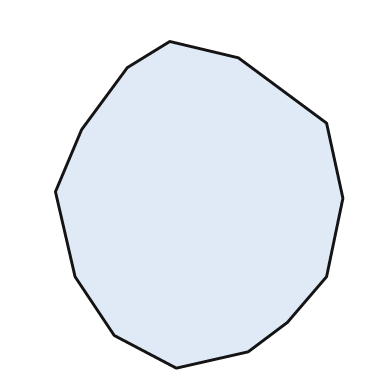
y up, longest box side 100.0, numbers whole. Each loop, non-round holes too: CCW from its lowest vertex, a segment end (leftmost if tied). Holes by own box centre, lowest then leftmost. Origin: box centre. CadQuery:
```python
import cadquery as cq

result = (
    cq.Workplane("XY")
    .moveTo(-7.0, -50.0)
    .lineTo(15.0, -45.0)
    .lineTo(27.0, -36.0)
    .lineTo(39.0, -22.0)
    .lineTo(44.0, 2.0)
    .lineTo(39.0, 25.0)
    .lineTo(12.0, 45.0)
    .lineTo(-9.0, 50.0)
    .lineTo(-22.0, 42.0)
    .lineTo(-36.0, 23.0)
    .lineTo(-44.0, 4.0)
    .lineTo(-38.0, -22.0)
    .lineTo(-26.0, -40.0)
    .close()
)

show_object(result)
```